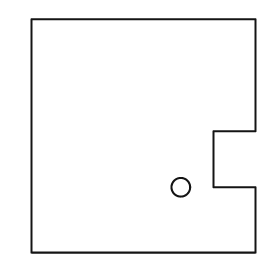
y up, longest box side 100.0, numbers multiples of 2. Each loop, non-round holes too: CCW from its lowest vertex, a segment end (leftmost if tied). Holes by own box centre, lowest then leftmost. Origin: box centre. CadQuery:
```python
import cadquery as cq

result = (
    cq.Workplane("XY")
    .moveTo(-48.0, -50.0)
    .lineTo(48.0, -50.0)
    .lineTo(48.0, -22.0)
    .lineTo(30.0, -22.0)
    .lineTo(30.0, 2.0)
    .lineTo(48.0, 2.0)
    .lineTo(48.0, 50.0)
    .lineTo(-48.0, 50.0)
    .close()
    .moveTo(16.0, -22.0)
    .circle(4.0)
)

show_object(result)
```